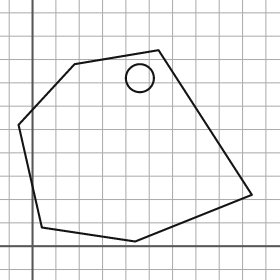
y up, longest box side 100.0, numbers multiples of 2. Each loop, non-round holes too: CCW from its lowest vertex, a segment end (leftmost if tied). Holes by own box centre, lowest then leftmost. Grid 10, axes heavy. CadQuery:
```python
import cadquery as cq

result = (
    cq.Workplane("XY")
    .moveTo(44.0, 2.0)
    .lineTo(94.0, 22.0)
    .lineTo(54.0, 84.0)
    .lineTo(18.0, 78.0)
    .lineTo(-6.0, 52.0)
    .lineTo(4.0, 8.0)
    .close()
    .moveTo(46.0, 72.0)
    .circle(6.0)
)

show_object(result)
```